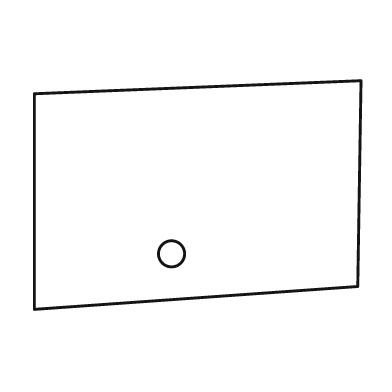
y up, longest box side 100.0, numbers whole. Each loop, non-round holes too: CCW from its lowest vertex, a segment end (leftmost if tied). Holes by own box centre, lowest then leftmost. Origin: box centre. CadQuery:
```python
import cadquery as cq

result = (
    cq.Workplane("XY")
    .moveTo(-50.0, -35.0)
    .lineTo(49.0, -28.0)
    .lineTo(50.0, 35.0)
    .lineTo(-50.0, 31.0)
    .close()
    .moveTo(-8.0, -18.0)
    .circle(4.0)
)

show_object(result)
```